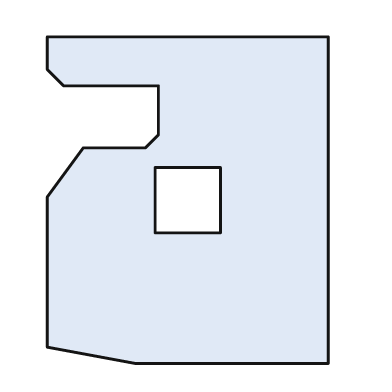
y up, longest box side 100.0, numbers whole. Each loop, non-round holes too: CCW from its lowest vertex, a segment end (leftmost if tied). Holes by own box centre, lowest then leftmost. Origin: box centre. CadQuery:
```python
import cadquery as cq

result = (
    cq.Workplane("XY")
    .moveTo(-16.0, -50.0)
    .lineTo(43.0, -50.0)
    .lineTo(43.0, 50.0)
    .lineTo(-43.0, 50.0)
    .lineTo(-43.0, 40.0)
    .lineTo(-38.0, 35.0)
    .lineTo(-9.0, 35.0)
    .lineTo(-9.0, 20.0)
    .lineTo(-13.0, 16.0)
    .lineTo(-32.0, 16.0)
    .lineTo(-43.0, 1.0)
    .lineTo(-43.0, -45.0)
    .close()
    .moveTo(-10.0, -10.0)
    .lineTo(10.0, -10.0)
    .lineTo(10.0, 10.0)
    .lineTo(-10.0, 10.0)
    .close()
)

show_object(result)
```